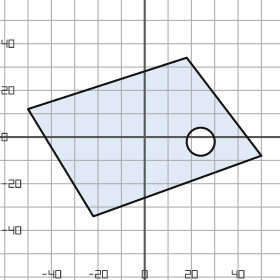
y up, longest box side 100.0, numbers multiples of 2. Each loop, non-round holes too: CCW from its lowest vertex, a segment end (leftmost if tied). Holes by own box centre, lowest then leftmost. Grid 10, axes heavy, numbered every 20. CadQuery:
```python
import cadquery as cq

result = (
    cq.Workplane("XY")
    .moveTo(-22.0, -34.0)
    .lineTo(50.0, -8.0)
    .lineTo(18.0, 34.0)
    .lineTo(-50.0, 12.0)
    .close()
    .moveTo(24.0, -2.0)
    .circle(6.0)
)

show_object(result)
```